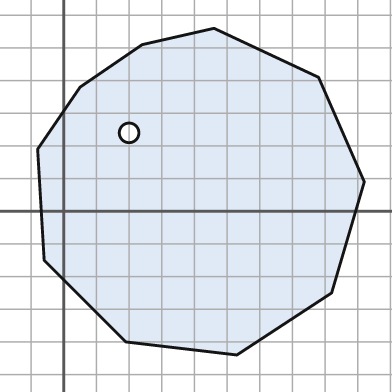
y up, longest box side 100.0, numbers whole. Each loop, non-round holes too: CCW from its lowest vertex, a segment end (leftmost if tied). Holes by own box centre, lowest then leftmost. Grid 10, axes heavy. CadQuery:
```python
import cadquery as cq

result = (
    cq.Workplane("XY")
    .moveTo(53.0, -44.0)
    .lineTo(82.0, -25.0)
    .lineTo(92.0, 9.0)
    .lineTo(78.0, 41.0)
    .lineTo(46.0, 56.0)
    .lineTo(24.0, 51.0)
    .lineTo(5.0, 38.0)
    .lineTo(-8.0, 19.0)
    .lineTo(-6.0, -15.0)
    .lineTo(19.0, -40.0)
    .close()
    .moveTo(20.0, 24.0)
    .circle(3.0)
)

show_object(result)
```